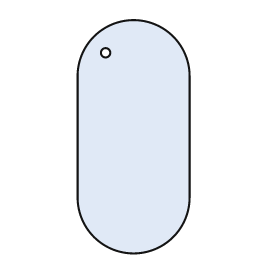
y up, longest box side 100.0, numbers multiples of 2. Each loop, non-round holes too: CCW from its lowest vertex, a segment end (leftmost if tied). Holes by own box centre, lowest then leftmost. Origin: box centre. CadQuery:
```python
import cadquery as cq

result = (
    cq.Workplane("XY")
    .moveTo(-24.0, -26.0)
    .threePointArc((0.0, -50.0), (24.0, -26.0))
    .lineTo(24.0, 26.0)
    .threePointArc((0.0, 50.0), (-24.0, 26.0))
    .close()
    .moveTo(-12.0, 36.0)
    .circle(2.0)
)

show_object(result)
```